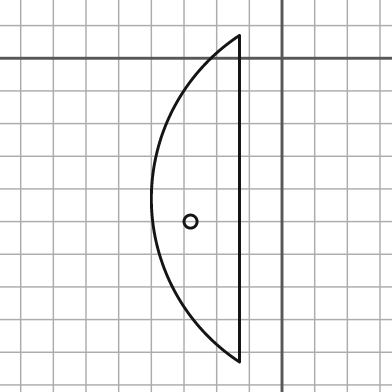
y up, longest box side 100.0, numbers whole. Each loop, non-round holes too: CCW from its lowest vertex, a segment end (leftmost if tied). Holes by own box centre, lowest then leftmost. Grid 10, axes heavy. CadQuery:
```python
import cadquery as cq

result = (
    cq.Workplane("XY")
    .moveTo(-13.0, -93.0)
    .lineTo(-13.0, 7.0)
    .threePointArc((-40.0, -43.0), (-13.0, -93.0))
    .close()
    .moveTo(-28.0, -50.0)
    .circle(2.0)
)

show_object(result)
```